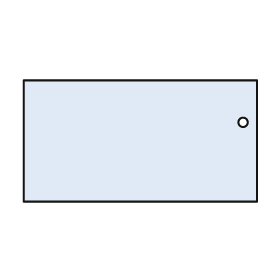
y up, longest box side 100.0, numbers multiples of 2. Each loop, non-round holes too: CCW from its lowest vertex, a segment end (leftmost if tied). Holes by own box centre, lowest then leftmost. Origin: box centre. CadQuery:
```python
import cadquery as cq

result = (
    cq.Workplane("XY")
    .moveTo(-50.0, -26.0)
    .lineTo(50.0, -26.0)
    .lineTo(50.0, 26.0)
    .lineTo(-50.0, 26.0)
    .close()
    .moveTo(44.0, 8.0)
    .circle(2.0)
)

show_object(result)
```